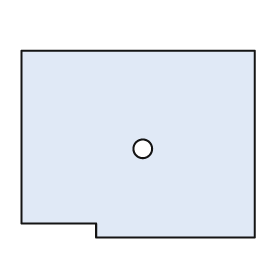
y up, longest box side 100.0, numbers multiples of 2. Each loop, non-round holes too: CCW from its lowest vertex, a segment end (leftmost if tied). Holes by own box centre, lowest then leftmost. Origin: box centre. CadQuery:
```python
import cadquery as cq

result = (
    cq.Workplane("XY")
    .moveTo(-18.0, -40.0)
    .lineTo(50.0, -40.0)
    .lineTo(50.0, 40.0)
    .lineTo(-50.0, 40.0)
    .lineTo(-50.0, -34.0)
    .lineTo(-18.0, -34.0)
    .close()
    .moveTo(2.0, -2.0)
    .circle(4.0)
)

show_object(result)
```